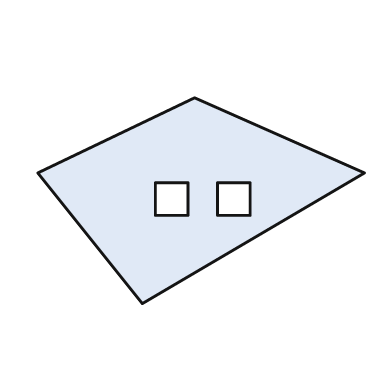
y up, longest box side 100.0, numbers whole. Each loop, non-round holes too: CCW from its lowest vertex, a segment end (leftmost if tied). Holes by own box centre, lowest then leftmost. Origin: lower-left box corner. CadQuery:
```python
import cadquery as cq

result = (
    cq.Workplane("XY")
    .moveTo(32.0, 0.0)
    .lineTo(100.0, 40.0)
    .lineTo(48.0, 63.0)
    .lineTo(0.0, 40.0)
    .close()
    .moveTo(36.0, 27.0)
    .lineTo(46.0, 27.0)
    .lineTo(46.0, 37.0)
    .lineTo(36.0, 37.0)
    .close()
    .moveTo(55.0, 27.0)
    .lineTo(65.0, 27.0)
    .lineTo(65.0, 37.0)
    .lineTo(55.0, 37.0)
    .close()
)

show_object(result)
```